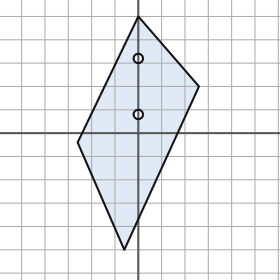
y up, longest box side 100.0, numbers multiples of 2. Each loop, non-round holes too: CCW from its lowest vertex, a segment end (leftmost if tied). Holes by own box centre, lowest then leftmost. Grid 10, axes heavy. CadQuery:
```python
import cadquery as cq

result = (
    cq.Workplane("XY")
    .moveTo(-6.0, -50.0)
    .lineTo(26.0, 20.0)
    .lineTo(0.0, 50.0)
    .lineTo(-26.0, -4.0)
    .close()
    .moveTo(0.0, 8.0)
    .circle(2.0)
    .moveTo(0.0, 32.0)
    .circle(2.0)
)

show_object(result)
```